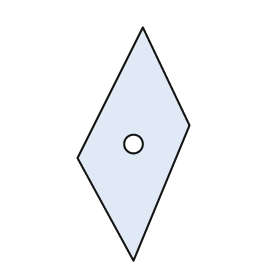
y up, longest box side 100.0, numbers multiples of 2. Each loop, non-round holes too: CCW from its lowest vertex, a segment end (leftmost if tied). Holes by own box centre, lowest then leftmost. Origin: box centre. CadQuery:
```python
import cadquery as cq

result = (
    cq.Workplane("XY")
    .moveTo(0.0, -50.0)
    .lineTo(24.0, 8.0)
    .lineTo(4.0, 50.0)
    .lineTo(-24.0, -6.0)
    .close()
    .moveTo(0.0, 0.0)
    .circle(4.0)
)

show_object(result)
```